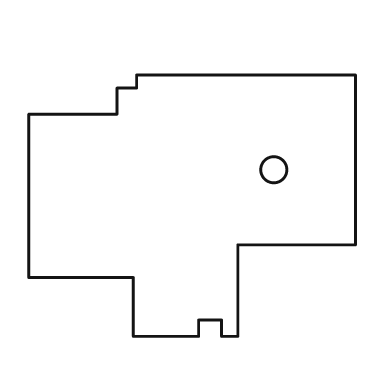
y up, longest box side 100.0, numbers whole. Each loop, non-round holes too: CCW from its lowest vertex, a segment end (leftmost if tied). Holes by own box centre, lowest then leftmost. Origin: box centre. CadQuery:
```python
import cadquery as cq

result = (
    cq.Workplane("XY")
    .moveTo(-18.0, -40.0)
    .lineTo(2.0, -40.0)
    .lineTo(2.0, -35.0)
    .lineTo(9.0, -35.0)
    .lineTo(9.0, -40.0)
    .lineTo(14.0, -40.0)
    .lineTo(14.0, -12.0)
    .lineTo(50.0, -12.0)
    .lineTo(50.0, 40.0)
    .lineTo(-17.0, 40.0)
    .lineTo(-17.0, 36.0)
    .lineTo(-23.0, 36.0)
    .lineTo(-23.0, 28.0)
    .lineTo(-50.0, 28.0)
    .lineTo(-50.0, -22.0)
    .lineTo(-18.0, -22.0)
    .close()
    .moveTo(25.0, 11.0)
    .circle(4.0)
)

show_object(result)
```